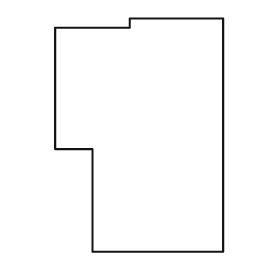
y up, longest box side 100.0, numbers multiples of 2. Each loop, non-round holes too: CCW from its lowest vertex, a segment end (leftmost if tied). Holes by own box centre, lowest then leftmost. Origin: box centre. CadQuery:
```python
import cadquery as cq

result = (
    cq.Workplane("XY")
    .moveTo(-20.0, -50.0)
    .lineTo(36.0, -50.0)
    .lineTo(36.0, 50.0)
    .lineTo(-4.0, 50.0)
    .lineTo(-4.0, 46.0)
    .lineTo(-36.0, 46.0)
    .lineTo(-36.0, -6.0)
    .lineTo(-20.0, -6.0)
    .close()
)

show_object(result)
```